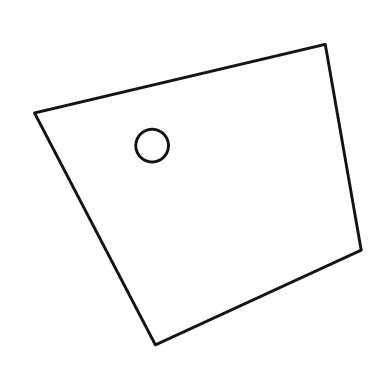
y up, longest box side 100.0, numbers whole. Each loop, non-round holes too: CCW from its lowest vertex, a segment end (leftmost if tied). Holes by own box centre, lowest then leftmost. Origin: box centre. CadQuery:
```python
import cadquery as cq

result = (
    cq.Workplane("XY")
    .moveTo(-13.0, -46.0)
    .lineTo(50.0, -17.0)
    .lineTo(39.0, 46.0)
    .lineTo(-50.0, 25.0)
    .close()
    .moveTo(-14.0, 15.0)
    .circle(5.0)
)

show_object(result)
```